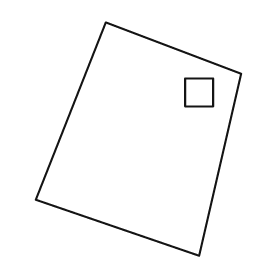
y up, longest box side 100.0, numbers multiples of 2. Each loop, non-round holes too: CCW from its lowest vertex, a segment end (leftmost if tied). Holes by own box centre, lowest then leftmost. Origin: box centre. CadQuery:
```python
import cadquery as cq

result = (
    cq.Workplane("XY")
    .moveTo(26.0, -50.0)
    .lineTo(44.0, 28.0)
    .lineTo(-14.0, 50.0)
    .lineTo(-44.0, -26.0)
    .close()
    .moveTo(20.0, 14.0)
    .lineTo(32.0, 14.0)
    .lineTo(32.0, 26.0)
    .lineTo(20.0, 26.0)
    .close()
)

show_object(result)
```